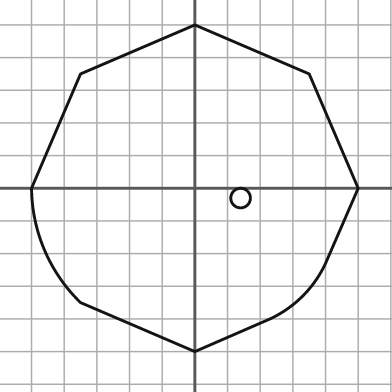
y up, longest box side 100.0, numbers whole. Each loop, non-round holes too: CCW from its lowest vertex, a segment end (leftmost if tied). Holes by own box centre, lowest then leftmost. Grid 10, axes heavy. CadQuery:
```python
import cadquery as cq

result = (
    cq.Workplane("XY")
    .moveTo(0.0, -50.0)
    .lineTo(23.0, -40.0)
    .threePointArc((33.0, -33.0), (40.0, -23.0))
    .lineTo(50.0, 0.0)
    .lineTo(35.0, 35.0)
    .lineTo(0.0, 50.0)
    .lineTo(-35.0, 35.0)
    .lineTo(-50.0, 0.0)
    .threePointArc((-46.0, -19.0), (-35.0, -35.0))
    .close()
    .moveTo(14.0, -3.0)
    .circle(3.0)
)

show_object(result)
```